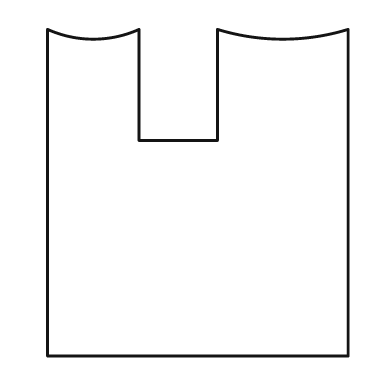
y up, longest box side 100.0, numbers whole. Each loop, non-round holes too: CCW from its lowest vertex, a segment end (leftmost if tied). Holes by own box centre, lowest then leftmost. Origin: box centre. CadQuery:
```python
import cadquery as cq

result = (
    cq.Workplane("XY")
    .moveTo(-46.0, -50.0)
    .lineTo(46.0, -50.0)
    .lineTo(46.0, 50.0)
    .threePointArc((26.0, 47.0), (6.0, 50.0))
    .lineTo(6.0, 16.0)
    .lineTo(-18.0, 16.0)
    .lineTo(-18.0, 50.0)
    .threePointArc((-32.0, 47.0), (-46.0, 50.0))
    .close()
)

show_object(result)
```